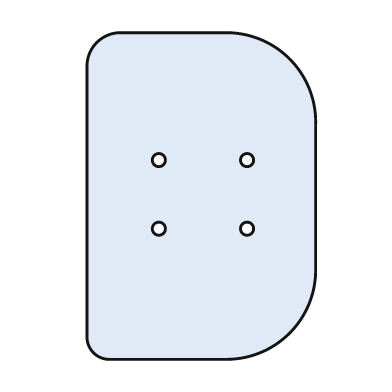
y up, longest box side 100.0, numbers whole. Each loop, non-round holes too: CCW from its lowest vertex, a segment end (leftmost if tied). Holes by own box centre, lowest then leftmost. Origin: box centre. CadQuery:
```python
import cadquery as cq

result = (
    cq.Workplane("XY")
    .moveTo(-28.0, -50.0)
    .lineTo(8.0, -50.0)
    .threePointArc((27.0, -42.0), (35.0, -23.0))
    .lineTo(35.0, 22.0)
    .threePointArc((27.0, 42.0), (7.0, 50.0))
    .lineTo(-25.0, 50.0)
    .threePointArc((-32.0, 47.0), (-35.0, 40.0))
    .lineTo(-35.0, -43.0)
    .threePointArc((-33.0, -48.0), (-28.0, -50.0))
    .close()
    .moveTo(-13.0, -10.0)
    .circle(2.0)
    .moveTo(14.0, -10.0)
    .circle(2.0)
    .moveTo(-13.0, 11.0)
    .circle(2.0)
    .moveTo(14.0, 11.0)
    .circle(2.0)
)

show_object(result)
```